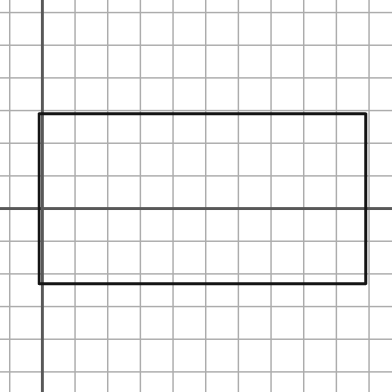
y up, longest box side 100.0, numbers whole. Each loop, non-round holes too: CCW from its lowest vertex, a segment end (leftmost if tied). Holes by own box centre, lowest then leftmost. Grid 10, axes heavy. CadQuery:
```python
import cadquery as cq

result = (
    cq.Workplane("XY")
    .moveTo(-1.0, -23.0)
    .lineTo(99.0, -23.0)
    .lineTo(99.0, 29.0)
    .lineTo(-1.0, 29.0)
    .close()
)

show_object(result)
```